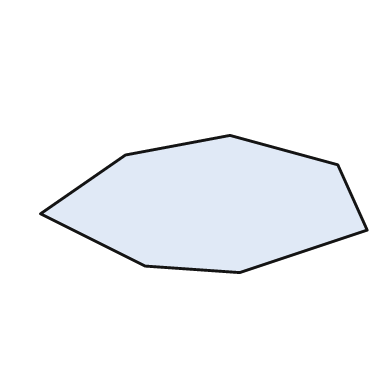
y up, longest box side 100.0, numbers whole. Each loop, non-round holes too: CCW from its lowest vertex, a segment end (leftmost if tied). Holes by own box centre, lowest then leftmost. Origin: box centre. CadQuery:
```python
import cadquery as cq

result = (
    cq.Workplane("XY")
    .moveTo(11.0, -21.0)
    .lineTo(50.0, -8.0)
    .lineTo(41.0, 12.0)
    .lineTo(8.0, 21.0)
    .lineTo(-24.0, 15.0)
    .lineTo(-50.0, -3.0)
    .lineTo(-18.0, -19.0)
    .close()
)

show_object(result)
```